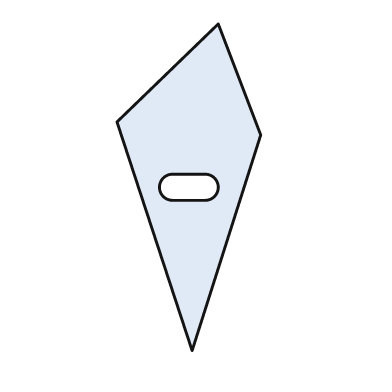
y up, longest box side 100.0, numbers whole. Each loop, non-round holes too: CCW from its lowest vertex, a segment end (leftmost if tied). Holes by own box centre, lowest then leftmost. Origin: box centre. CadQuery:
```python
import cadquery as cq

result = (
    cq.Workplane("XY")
    .moveTo(1.0, -50.0)
    .lineTo(22.0, 16.0)
    .lineTo(9.0, 50.0)
    .lineTo(-22.0, 20.0)
    .close()
    .moveTo(-5.0, -4.0)
    .lineTo(5.0, -4.0)
    .threePointArc((9.0, 0.0), (5.0, 4.0))
    .lineTo(-5.0, 4.0)
    .threePointArc((-9.0, 0.0), (-5.0, -4.0))
    .close()
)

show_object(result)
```